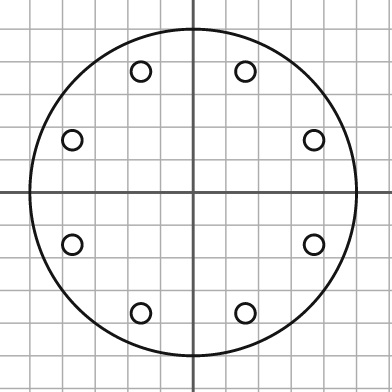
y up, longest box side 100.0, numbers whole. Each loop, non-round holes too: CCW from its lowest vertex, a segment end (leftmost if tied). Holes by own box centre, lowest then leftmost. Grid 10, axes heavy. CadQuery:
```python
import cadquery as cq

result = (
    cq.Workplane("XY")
    .moveTo(0.0, 0.0)
    .circle(50.0)
    .moveTo(-16.0, -37.0)
    .circle(3.0)
    .moveTo(16.0, -37.0)
    .circle(3.0)
    .moveTo(-37.0, -16.0)
    .circle(3.0)
    .moveTo(37.0, -16.0)
    .circle(3.0)
    .moveTo(-37.0, 16.0)
    .circle(3.0)
    .moveTo(37.0, 16.0)
    .circle(3.0)
    .moveTo(-16.0, 37.0)
    .circle(3.0)
    .moveTo(16.0, 37.0)
    .circle(3.0)
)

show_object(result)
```